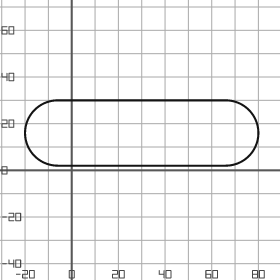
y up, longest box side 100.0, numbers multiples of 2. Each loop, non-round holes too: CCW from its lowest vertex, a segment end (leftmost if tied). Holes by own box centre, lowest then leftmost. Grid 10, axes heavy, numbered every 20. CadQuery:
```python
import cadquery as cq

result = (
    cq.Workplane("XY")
    .moveTo(-6.0, 2.0)
    .lineTo(66.0, 2.0)
    .threePointArc((80.0, 16.0), (66.0, 30.0))
    .lineTo(-6.0, 30.0)
    .threePointArc((-20.0, 16.0), (-6.0, 2.0))
    .close()
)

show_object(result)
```